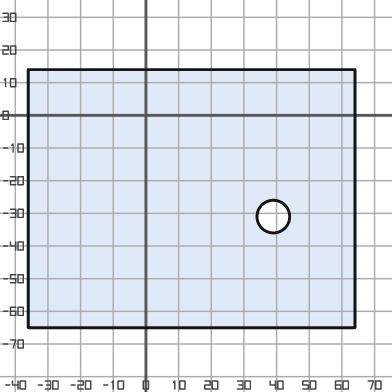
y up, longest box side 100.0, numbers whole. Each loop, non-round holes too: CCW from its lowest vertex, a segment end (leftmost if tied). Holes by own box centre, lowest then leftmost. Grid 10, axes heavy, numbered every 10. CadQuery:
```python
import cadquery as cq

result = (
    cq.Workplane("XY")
    .moveTo(-36.0, -65.0)
    .lineTo(64.0, -65.0)
    .lineTo(64.0, 14.0)
    .lineTo(-36.0, 14.0)
    .close()
    .moveTo(39.0, -31.0)
    .circle(5.0)
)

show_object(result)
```